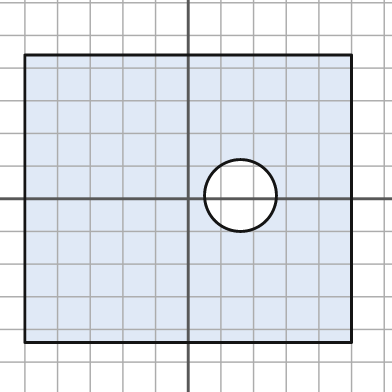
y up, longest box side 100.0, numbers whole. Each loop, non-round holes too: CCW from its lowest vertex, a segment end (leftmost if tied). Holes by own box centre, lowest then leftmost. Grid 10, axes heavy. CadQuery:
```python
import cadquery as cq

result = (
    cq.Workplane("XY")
    .moveTo(-50.0, -44.0)
    .lineTo(50.0, -44.0)
    .lineTo(50.0, 44.0)
    .lineTo(-50.0, 44.0)
    .close()
    .moveTo(16.0, 1.0)
    .circle(11.0)
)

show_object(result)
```